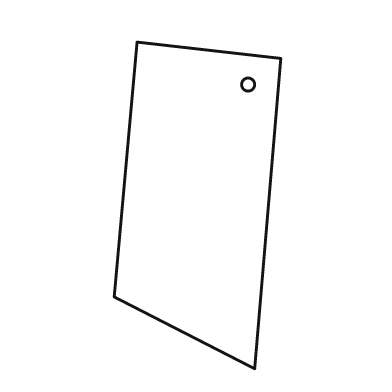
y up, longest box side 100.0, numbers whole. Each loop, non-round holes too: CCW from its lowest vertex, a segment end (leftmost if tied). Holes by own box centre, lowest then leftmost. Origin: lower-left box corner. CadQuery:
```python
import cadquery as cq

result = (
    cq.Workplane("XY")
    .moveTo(43.0, 0.0)
    .lineTo(51.0, 95.0)
    .lineTo(7.0, 100.0)
    .lineTo(0.0, 22.0)
    .close()
    .moveTo(41.0, 87.0)
    .circle(2.0)
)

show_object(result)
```